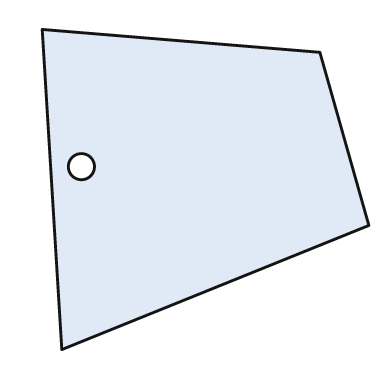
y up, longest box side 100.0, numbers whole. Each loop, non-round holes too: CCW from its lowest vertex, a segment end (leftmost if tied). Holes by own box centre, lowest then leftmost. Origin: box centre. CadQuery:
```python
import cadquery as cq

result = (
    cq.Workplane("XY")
    .moveTo(-44.0, -49.0)
    .lineTo(50.0, -11.0)
    .lineTo(35.0, 42.0)
    .lineTo(-50.0, 49.0)
    .close()
    .moveTo(-38.0, 7.0)
    .circle(4.0)
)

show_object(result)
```